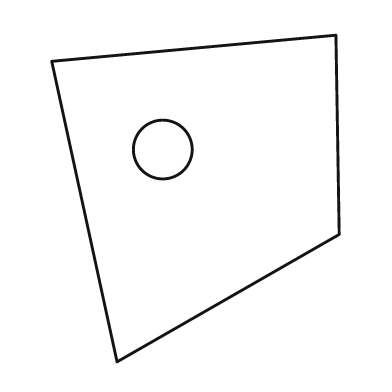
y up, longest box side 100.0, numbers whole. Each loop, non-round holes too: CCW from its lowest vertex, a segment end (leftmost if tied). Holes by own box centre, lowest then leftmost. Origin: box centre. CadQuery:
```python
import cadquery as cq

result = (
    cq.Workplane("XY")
    .moveTo(-24.0, -50.0)
    .lineTo(44.0, -11.0)
    .lineTo(43.0, 50.0)
    .lineTo(-44.0, 42.0)
    .close()
    .moveTo(-10.0, 15.0)
    .circle(9.0)
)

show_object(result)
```